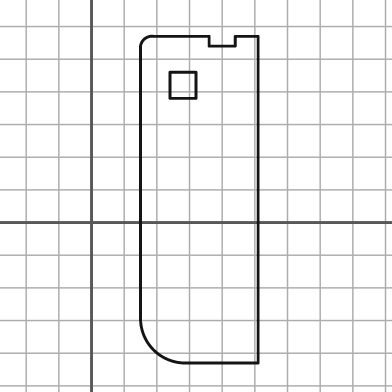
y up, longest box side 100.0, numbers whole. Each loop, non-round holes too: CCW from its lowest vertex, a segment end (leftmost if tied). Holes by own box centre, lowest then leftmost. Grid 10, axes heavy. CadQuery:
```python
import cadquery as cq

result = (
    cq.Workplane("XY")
    .moveTo(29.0, -43.0)
    .lineTo(51.0, -43.0)
    .lineTo(51.0, 57.0)
    .lineTo(44.0, 57.0)
    .lineTo(44.0, 54.0)
    .lineTo(36.0, 54.0)
    .lineTo(36.0, 57.0)
    .lineTo(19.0, 57.0)
    .threePointArc((16.0, 56.0), (15.0, 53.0))
    .lineTo(15.0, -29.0)
    .threePointArc((19.0, -39.0), (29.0, -43.0))
    .close()
    .moveTo(24.0, 38.0)
    .lineTo(32.0, 38.0)
    .lineTo(32.0, 46.0)
    .lineTo(24.0, 46.0)
    .close()
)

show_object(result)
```